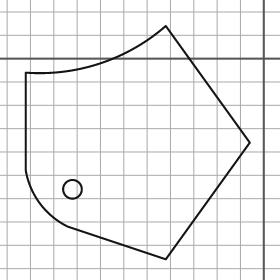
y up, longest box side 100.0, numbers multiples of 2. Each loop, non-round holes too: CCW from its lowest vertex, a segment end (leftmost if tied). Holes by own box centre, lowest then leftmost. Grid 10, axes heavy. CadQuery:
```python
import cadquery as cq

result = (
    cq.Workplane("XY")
    .moveTo(-42.0, -86.0)
    .lineTo(-6.0, -36.0)
    .lineTo(-42.0, 14.0)
    .threePointArc((-70.0, -2.0), (-102.0, -6.0))
    .lineTo(-102.0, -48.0)
    .threePointArc((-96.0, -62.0), (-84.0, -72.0))
    .close()
    .moveTo(-82.0, -56.0)
    .circle(4.0)
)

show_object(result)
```